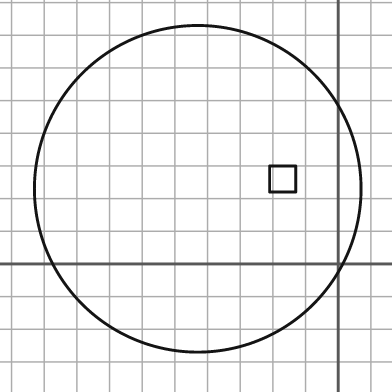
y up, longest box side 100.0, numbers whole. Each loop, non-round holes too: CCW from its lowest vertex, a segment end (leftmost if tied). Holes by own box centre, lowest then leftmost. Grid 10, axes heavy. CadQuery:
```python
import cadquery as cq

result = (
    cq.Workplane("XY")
    .moveTo(-43.0, 23.0)
    .circle(50.0)
    .moveTo(-21.0, 22.0)
    .lineTo(-13.0, 22.0)
    .lineTo(-13.0, 30.0)
    .lineTo(-21.0, 30.0)
    .close()
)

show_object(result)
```